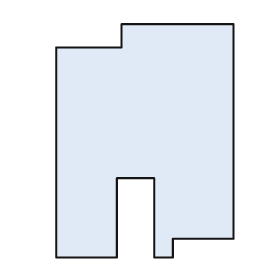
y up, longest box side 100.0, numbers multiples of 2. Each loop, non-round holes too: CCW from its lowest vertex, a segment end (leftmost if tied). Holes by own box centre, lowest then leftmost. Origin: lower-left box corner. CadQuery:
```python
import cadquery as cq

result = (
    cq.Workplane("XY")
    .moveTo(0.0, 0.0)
    .lineTo(26.0, 0.0)
    .lineTo(26.0, 34.0)
    .lineTo(42.0, 34.0)
    .lineTo(42.0, 0.0)
    .lineTo(50.0, 0.0)
    .lineTo(50.0, 8.0)
    .lineTo(76.0, 8.0)
    .lineTo(76.0, 100.0)
    .lineTo(28.0, 100.0)
    .lineTo(28.0, 90.0)
    .lineTo(0.0, 90.0)
    .close()
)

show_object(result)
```